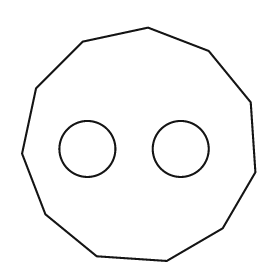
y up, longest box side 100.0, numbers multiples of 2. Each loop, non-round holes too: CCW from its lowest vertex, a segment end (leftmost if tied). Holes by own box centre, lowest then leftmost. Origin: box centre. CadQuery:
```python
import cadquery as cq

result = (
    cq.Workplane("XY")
    .moveTo(12.0, -50.0)
    .lineTo(36.0, -36.0)
    .lineTo(50.0, -12.0)
    .lineTo(48.0, 18.0)
    .lineTo(30.0, 40.0)
    .lineTo(4.0, 50.0)
    .lineTo(-24.0, 44.0)
    .lineTo(-44.0, 24.0)
    .lineTo(-50.0, -4.0)
    .lineTo(-40.0, -30.0)
    .lineTo(-18.0, -48.0)
    .close()
    .moveTo(-22.0, -2.0)
    .circle(12.0)
    .moveTo(18.0, -2.0)
    .circle(12.0)
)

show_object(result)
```